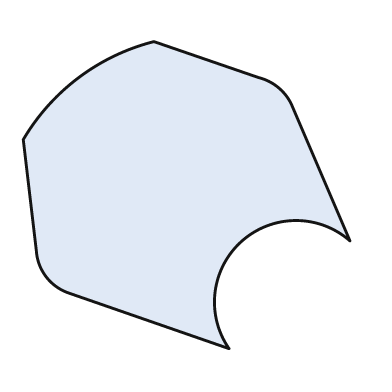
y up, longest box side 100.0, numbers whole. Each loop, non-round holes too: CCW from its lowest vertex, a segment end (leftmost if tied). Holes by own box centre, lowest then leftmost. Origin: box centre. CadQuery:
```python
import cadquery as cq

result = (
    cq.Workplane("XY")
    .moveTo(13.0, -47.0)
    .threePointArc((17.0, -14.0), (50.0, -14.0))
    .lineTo(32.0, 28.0)
    .threePointArc((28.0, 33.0), (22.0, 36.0))
    .lineTo(-10.0, 47.0)
    .threePointArc((-33.0, 36.0), (-50.0, 17.0))
    .lineTo(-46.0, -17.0)
    .threePointArc((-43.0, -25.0), (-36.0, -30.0))
    .close()
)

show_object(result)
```